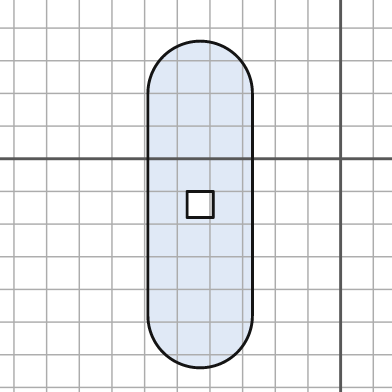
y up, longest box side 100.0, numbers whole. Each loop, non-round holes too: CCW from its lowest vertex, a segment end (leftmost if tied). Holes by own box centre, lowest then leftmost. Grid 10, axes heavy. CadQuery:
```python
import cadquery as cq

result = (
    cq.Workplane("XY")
    .moveTo(-59.0, -48.0)
    .threePointArc((-43.0, -64.0), (-27.0, -48.0))
    .lineTo(-27.0, 20.0)
    .threePointArc((-43.0, 36.0), (-59.0, 20.0))
    .close()
    .moveTo(-47.0, -18.0)
    .lineTo(-39.0, -18.0)
    .lineTo(-39.0, -10.0)
    .lineTo(-47.0, -10.0)
    .close()
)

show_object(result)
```